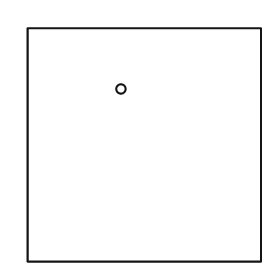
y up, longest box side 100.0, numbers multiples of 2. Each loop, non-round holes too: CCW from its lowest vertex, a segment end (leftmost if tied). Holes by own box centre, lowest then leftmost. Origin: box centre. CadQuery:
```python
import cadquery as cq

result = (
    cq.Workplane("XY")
    .moveTo(-50.0, -50.0)
    .lineTo(50.0, -50.0)
    .lineTo(50.0, 50.0)
    .lineTo(-50.0, 50.0)
    .close()
    .moveTo(-10.0, 24.0)
    .circle(2.0)
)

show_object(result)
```